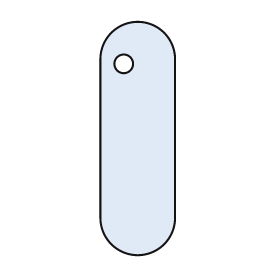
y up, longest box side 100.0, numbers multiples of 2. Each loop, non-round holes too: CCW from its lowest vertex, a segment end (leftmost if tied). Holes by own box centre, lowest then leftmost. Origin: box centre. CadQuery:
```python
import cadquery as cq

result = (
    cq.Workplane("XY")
    .moveTo(-16.0, -34.0)
    .threePointArc((0.0, -50.0), (16.0, -34.0))
    .lineTo(16.0, 34.0)
    .threePointArc((0.0, 50.0), (-16.0, 34.0))
    .close()
    .moveTo(-6.0, 32.0)
    .circle(4.0)
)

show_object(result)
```